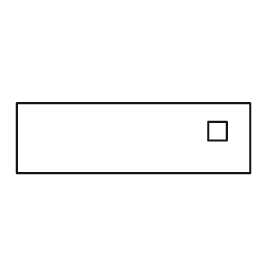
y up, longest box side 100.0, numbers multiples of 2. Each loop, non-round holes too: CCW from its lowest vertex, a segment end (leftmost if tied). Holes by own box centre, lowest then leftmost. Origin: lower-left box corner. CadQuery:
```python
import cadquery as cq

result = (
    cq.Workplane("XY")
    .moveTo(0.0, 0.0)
    .lineTo(100.0, 0.0)
    .lineTo(100.0, 30.0)
    .lineTo(0.0, 30.0)
    .close()
    .moveTo(82.0, 14.0)
    .lineTo(90.0, 14.0)
    .lineTo(90.0, 22.0)
    .lineTo(82.0, 22.0)
    .close()
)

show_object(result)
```